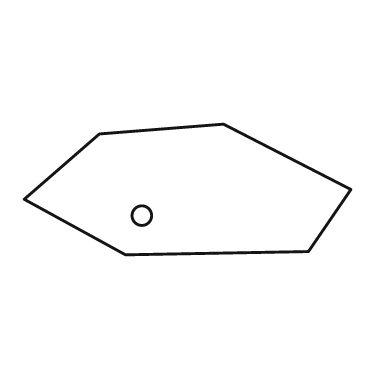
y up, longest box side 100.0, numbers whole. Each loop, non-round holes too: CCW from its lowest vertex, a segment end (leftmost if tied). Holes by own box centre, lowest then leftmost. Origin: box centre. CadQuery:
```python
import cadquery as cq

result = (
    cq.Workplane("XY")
    .moveTo(-19.0, -20.0)
    .lineTo(37.0, -19.0)
    .lineTo(50.0, 0.0)
    .lineTo(11.0, 20.0)
    .lineTo(-27.0, 17.0)
    .lineTo(-50.0, -3.0)
    .close()
    .moveTo(-14.0, -8.0)
    .circle(3.0)
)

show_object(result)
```